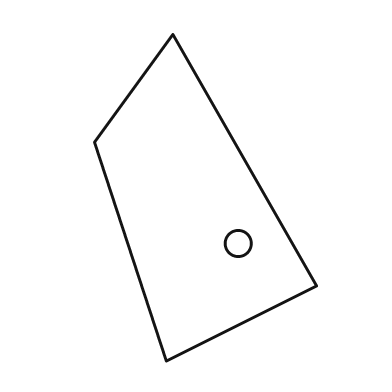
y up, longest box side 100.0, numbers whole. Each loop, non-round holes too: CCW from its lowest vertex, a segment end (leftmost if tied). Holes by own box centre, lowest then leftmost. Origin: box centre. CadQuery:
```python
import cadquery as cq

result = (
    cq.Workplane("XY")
    .moveTo(-12.0, -50.0)
    .lineTo(34.0, -27.0)
    .lineTo(-10.0, 50.0)
    .lineTo(-34.0, 17.0)
    .close()
    .moveTo(10.0, -14.0)
    .circle(4.0)
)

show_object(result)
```